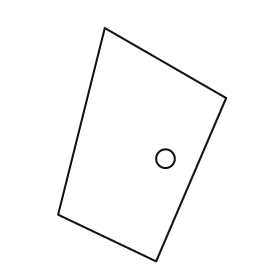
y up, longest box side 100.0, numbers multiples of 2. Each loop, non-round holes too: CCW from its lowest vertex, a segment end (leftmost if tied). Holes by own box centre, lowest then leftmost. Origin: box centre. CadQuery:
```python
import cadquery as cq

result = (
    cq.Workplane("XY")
    .moveTo(6.0, -50.0)
    .lineTo(36.0, 20.0)
    .lineTo(-16.0, 50.0)
    .lineTo(-36.0, -30.0)
    .close()
    .moveTo(10.0, -6.0)
    .circle(4.0)
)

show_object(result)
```